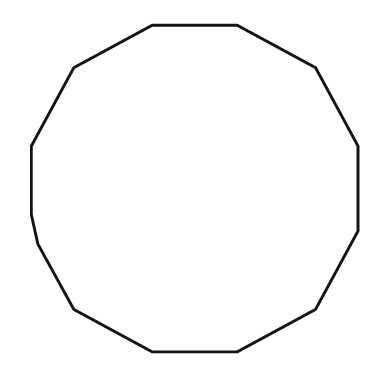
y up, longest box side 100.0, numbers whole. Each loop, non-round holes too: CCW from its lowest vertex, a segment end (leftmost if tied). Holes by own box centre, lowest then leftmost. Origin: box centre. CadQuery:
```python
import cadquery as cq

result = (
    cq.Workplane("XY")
    .moveTo(-13.0, -50.0)
    .lineTo(13.0, -50.0)
    .lineTo(37.0, -37.0)
    .lineTo(50.0, -13.0)
    .lineTo(50.0, 13.0)
    .lineTo(37.0, 37.0)
    .lineTo(13.0, 50.0)
    .lineTo(-13.0, 50.0)
    .lineTo(-37.0, 37.0)
    .lineTo(-50.0, 13.0)
    .lineTo(-50.0, -8.0)
    .lineTo(-48.0, -17.0)
    .lineTo(-37.0, -37.0)
    .close()
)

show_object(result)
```